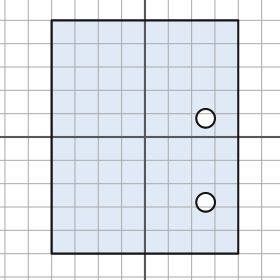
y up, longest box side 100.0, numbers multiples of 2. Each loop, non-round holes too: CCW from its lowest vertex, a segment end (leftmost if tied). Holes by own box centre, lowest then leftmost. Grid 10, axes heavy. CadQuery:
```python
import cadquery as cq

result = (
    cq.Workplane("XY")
    .moveTo(-40.0, -50.0)
    .lineTo(40.0, -50.0)
    .lineTo(40.0, 50.0)
    .lineTo(-40.0, 50.0)
    .close()
    .moveTo(26.0, -28.0)
    .circle(4.0)
    .moveTo(26.0, 8.0)
    .circle(4.0)
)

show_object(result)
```